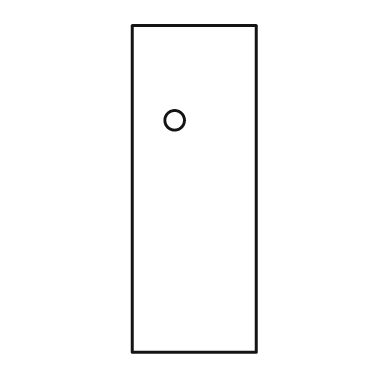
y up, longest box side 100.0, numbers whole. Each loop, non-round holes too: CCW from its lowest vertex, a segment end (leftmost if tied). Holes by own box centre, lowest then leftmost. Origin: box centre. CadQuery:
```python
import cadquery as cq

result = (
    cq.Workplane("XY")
    .moveTo(-19.0, -50.0)
    .lineTo(19.0, -50.0)
    .lineTo(19.0, 50.0)
    .lineTo(-19.0, 50.0)
    .close()
    .moveTo(-6.0, 21.0)
    .circle(3.0)
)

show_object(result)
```